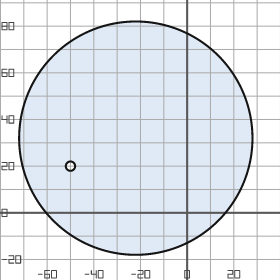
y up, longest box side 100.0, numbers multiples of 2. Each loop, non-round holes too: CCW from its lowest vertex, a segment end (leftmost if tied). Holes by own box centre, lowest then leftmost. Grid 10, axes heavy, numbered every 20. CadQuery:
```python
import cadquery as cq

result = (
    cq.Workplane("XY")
    .moveTo(-22.0, 32.0)
    .circle(50.0)
    .moveTo(-50.0, 20.0)
    .circle(2.0)
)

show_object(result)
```